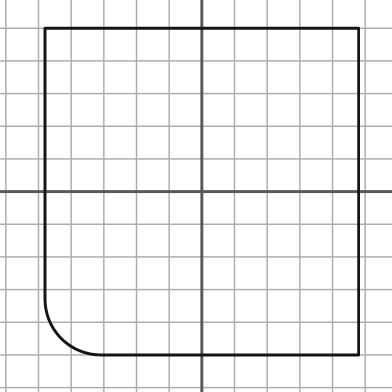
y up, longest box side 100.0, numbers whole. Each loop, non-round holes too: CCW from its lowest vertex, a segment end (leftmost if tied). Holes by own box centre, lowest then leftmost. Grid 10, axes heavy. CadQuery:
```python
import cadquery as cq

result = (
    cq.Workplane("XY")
    .moveTo(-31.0, -50.0)
    .lineTo(48.0, -50.0)
    .lineTo(48.0, 50.0)
    .lineTo(-48.0, 50.0)
    .lineTo(-48.0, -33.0)
    .threePointArc((-43.0, -45.0), (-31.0, -50.0))
    .close()
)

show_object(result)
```